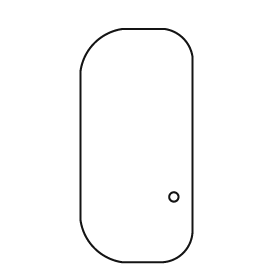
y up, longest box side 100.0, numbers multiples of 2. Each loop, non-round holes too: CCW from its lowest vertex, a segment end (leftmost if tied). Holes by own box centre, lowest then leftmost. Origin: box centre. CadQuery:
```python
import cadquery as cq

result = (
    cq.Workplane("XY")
    .moveTo(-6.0, -50.0)
    .lineTo(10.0, -50.0)
    .threePointArc((20.0, -46.0), (24.0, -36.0))
    .lineTo(24.0, 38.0)
    .threePointArc((20.0, 46.0), (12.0, 50.0))
    .lineTo(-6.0, 50.0)
    .threePointArc((-18.0, 44.0), (-24.0, 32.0))
    .lineTo(-24.0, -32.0)
    .threePointArc((-18.0, -44.0), (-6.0, -50.0))
    .close()
    .moveTo(16.0, -22.0)
    .circle(2.0)
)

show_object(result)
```